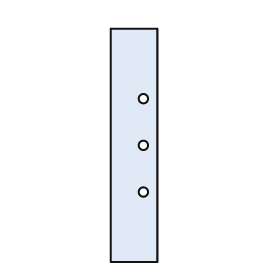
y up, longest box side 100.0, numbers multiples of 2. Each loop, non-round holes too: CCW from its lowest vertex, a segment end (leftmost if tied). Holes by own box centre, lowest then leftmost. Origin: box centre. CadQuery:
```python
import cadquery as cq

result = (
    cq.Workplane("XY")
    .moveTo(-10.0, -50.0)
    .lineTo(10.0, -50.0)
    .lineTo(10.0, 50.0)
    .lineTo(-10.0, 50.0)
    .close()
    .moveTo(4.0, -20.0)
    .circle(2.0)
    .moveTo(4.0, 0.0)
    .circle(2.0)
    .moveTo(4.0, 20.0)
    .circle(2.0)
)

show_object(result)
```